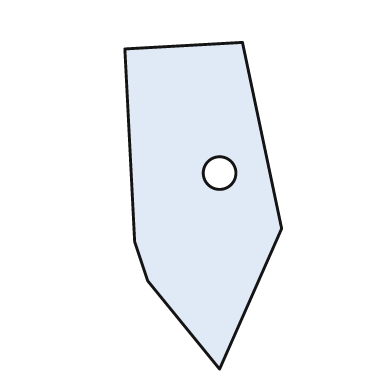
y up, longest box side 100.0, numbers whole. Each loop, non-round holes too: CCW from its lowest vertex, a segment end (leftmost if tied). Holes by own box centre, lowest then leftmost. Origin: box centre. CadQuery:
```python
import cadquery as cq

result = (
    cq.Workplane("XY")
    .moveTo(5.0, -50.0)
    .lineTo(24.0, -7.0)
    .lineTo(12.0, 50.0)
    .lineTo(-24.0, 48.0)
    .lineTo(-21.0, -11.0)
    .lineTo(-17.0, -23.0)
    .close()
    .moveTo(5.0, 10.0)
    .circle(5.0)
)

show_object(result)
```